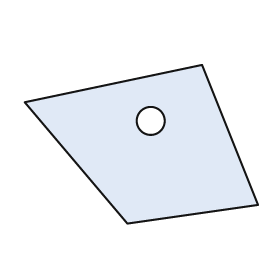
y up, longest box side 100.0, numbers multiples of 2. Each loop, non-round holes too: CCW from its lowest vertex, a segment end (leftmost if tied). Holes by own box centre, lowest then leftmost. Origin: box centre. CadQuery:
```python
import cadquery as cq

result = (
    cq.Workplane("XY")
    .moveTo(-6.0, -34.0)
    .lineTo(50.0, -26.0)
    .lineTo(26.0, 34.0)
    .lineTo(-50.0, 18.0)
    .close()
    .moveTo(4.0, 10.0)
    .circle(6.0)
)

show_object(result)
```